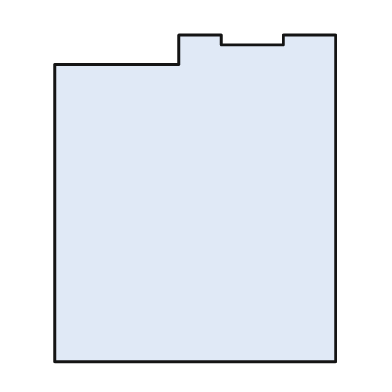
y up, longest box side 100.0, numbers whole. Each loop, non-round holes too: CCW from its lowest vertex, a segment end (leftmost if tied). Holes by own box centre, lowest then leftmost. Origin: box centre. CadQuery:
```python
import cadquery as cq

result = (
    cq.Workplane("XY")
    .moveTo(-43.0, -50.0)
    .lineTo(43.0, -50.0)
    .lineTo(43.0, 50.0)
    .lineTo(27.0, 50.0)
    .lineTo(27.0, 47.0)
    .lineTo(8.0, 47.0)
    .lineTo(8.0, 50.0)
    .lineTo(-5.0, 50.0)
    .lineTo(-5.0, 41.0)
    .lineTo(-43.0, 41.0)
    .close()
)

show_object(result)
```